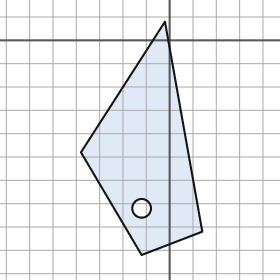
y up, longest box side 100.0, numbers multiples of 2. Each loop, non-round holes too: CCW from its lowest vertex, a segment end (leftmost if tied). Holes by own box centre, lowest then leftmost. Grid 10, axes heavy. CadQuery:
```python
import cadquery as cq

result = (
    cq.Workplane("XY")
    .moveTo(-12.0, -92.0)
    .lineTo(14.0, -82.0)
    .lineTo(-2.0, 8.0)
    .lineTo(-38.0, -48.0)
    .close()
    .moveTo(-12.0, -72.0)
    .circle(4.0)
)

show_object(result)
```